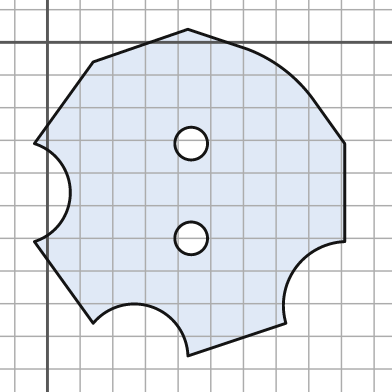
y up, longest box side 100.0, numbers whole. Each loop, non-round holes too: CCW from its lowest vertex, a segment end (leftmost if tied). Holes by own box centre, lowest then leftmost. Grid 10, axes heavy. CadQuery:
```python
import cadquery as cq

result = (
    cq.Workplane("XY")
    .moveTo(43.0, -96.0)
    .lineTo(73.0, -86.0)
    .threePointArc((76.0, -69.0), (91.0, -61.0))
    .lineTo(91.0, -31.0)
    .lineTo(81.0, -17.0)
    .threePointArc((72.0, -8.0), (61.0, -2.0))
    .lineTo(43.0, 4.0)
    .lineTo(14.0, -6.0)
    .lineTo(-4.0, -31.0)
    .threePointArc((7.0, -46.0), (-4.0, -61.0))
    .lineTo(14.0, -86.0)
    .threePointArc((32.0, -81.0), (43.0, -96.0))
    .close()
    .moveTo(44.0, -60.0)
    .circle(5.0)
    .moveTo(44.0, -31.0)
    .circle(5.0)
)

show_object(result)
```